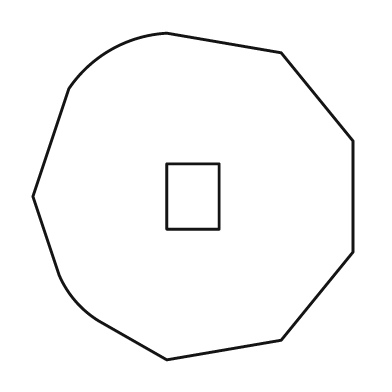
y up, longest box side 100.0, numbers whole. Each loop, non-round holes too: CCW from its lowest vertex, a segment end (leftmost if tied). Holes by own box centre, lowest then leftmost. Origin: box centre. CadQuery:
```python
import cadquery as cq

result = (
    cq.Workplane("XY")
    .moveTo(-8.0, -50.0)
    .lineTo(27.0, -44.0)
    .lineTo(49.0, -17.0)
    .lineTo(49.0, 17.0)
    .lineTo(27.0, 44.0)
    .lineTo(-8.0, 50.0)
    .threePointArc((-25.0, 45.0), (-38.0, 33.0))
    .lineTo(-49.0, 0.0)
    .lineTo(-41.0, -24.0)
    .threePointArc((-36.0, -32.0), (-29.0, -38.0))
    .close()
    .moveTo(-8.0, -10.0)
    .lineTo(8.0, -10.0)
    .lineTo(8.0, 10.0)
    .lineTo(-8.0, 10.0)
    .close()
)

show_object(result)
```